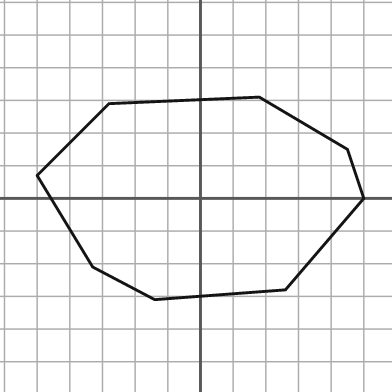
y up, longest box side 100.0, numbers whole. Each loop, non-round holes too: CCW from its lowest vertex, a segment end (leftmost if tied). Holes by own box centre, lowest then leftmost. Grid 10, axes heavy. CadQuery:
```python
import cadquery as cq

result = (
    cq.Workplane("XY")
    .moveTo(-14.0, -31.0)
    .lineTo(26.0, -28.0)
    .lineTo(50.0, 0.0)
    .lineTo(45.0, 15.0)
    .lineTo(18.0, 31.0)
    .lineTo(-28.0, 29.0)
    .lineTo(-50.0, 7.0)
    .lineTo(-33.0, -21.0)
    .close()
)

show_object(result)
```